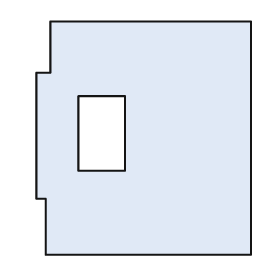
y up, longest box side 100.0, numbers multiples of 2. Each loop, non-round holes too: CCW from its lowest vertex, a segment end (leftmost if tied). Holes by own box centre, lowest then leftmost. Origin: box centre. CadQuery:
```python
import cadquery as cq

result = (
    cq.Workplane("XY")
    .moveTo(-42.0, -50.0)
    .lineTo(46.0, -50.0)
    .lineTo(46.0, 50.0)
    .lineTo(-40.0, 50.0)
    .lineTo(-40.0, 28.0)
    .lineTo(-46.0, 28.0)
    .lineTo(-46.0, -26.0)
    .lineTo(-42.0, -26.0)
    .close()
    .moveTo(-28.0, -14.0)
    .lineTo(-8.0, -14.0)
    .lineTo(-8.0, 18.0)
    .lineTo(-28.0, 18.0)
    .close()
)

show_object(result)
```